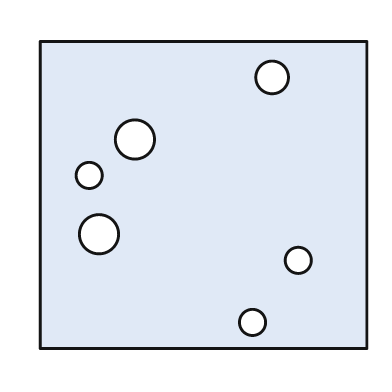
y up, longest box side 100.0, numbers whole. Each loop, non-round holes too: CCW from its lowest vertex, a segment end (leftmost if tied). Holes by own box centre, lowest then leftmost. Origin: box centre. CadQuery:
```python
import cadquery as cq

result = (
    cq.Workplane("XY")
    .moveTo(-50.0, -47.0)
    .lineTo(50.0, -47.0)
    .lineTo(50.0, 47.0)
    .lineTo(-50.0, 47.0)
    .close()
    .moveTo(15.0, -39.0)
    .circle(4.0)
    .moveTo(29.0, -20.0)
    .circle(4.0)
    .moveTo(-32.0, -12.0)
    .circle(6.0)
    .moveTo(-35.0, 6.0)
    .circle(4.0)
    .moveTo(-21.0, 17.0)
    .circle(6.0)
    .moveTo(21.0, 36.0)
    .circle(5.0)
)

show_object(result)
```